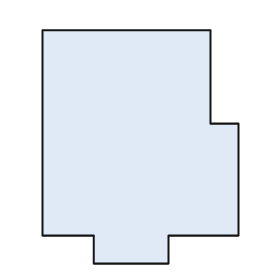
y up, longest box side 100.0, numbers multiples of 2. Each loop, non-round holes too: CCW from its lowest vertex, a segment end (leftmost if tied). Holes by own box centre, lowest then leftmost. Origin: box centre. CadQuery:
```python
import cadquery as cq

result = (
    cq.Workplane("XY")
    .moveTo(-20.0, -50.0)
    .lineTo(12.0, -50.0)
    .lineTo(12.0, -38.0)
    .lineTo(42.0, -38.0)
    .lineTo(42.0, 10.0)
    .lineTo(30.0, 10.0)
    .lineTo(30.0, 50.0)
    .lineTo(-42.0, 50.0)
    .lineTo(-42.0, -38.0)
    .lineTo(-20.0, -38.0)
    .close()
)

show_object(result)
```